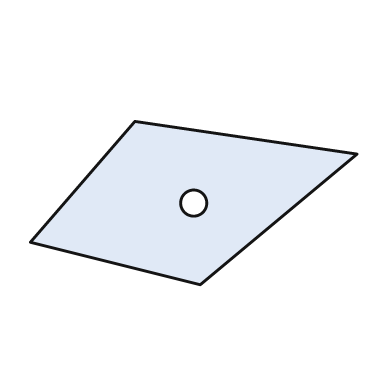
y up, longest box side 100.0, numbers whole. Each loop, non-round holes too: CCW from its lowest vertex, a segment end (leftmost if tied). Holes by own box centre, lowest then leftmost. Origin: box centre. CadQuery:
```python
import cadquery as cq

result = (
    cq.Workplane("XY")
    .moveTo(2.0, -25.0)
    .lineTo(50.0, 15.0)
    .lineTo(-18.0, 25.0)
    .lineTo(-50.0, -12.0)
    .close()
    .moveTo(0.0, 0.0)
    .circle(4.0)
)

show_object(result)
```